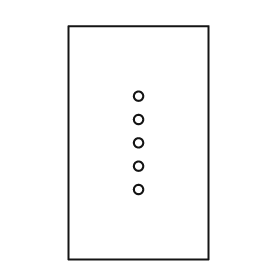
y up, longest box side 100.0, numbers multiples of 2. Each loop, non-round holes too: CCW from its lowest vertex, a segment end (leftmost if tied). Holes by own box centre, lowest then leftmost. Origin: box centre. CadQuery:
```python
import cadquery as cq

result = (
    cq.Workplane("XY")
    .moveTo(-30.0, -50.0)
    .lineTo(30.0, -50.0)
    .lineTo(30.0, 50.0)
    .lineTo(-30.0, 50.0)
    .close()
    .moveTo(0.0, -20.0)
    .circle(2.0)
    .moveTo(0.0, -10.0)
    .circle(2.0)
    .moveTo(0.0, 0.0)
    .circle(2.0)
    .moveTo(0.0, 10.0)
    .circle(2.0)
    .moveTo(0.0, 20.0)
    .circle(2.0)
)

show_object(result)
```